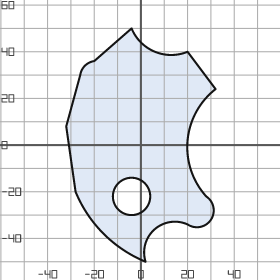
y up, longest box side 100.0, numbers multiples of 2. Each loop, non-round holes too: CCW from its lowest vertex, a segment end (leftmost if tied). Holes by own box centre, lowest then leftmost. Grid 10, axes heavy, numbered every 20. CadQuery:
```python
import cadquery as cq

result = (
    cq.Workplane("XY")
    .moveTo(2.0, -50.0)
    .threePointArc((6.0, -36.0), (20.0, -34.0))
    .threePointArc((30.0, -32.0), (28.0, -22.0))
    .threePointArc((20.0, 2.0), (32.0, 24.0))
    .lineTo(20.0, 40.0)
    .threePointArc((6.0, 40.0), (-4.0, 50.0))
    .lineTo(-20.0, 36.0)
    .threePointArc((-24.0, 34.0), (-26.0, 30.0))
    .lineTo(-32.0, 8.0)
    .lineTo(-28.0, -20.0)
    .threePointArc((-16.0, -38.0), (2.0, -50.0))
    .close()
    .moveTo(-4.0, -22.0)
    .circle(8.0)
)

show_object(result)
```